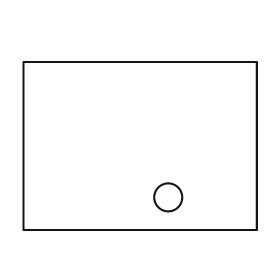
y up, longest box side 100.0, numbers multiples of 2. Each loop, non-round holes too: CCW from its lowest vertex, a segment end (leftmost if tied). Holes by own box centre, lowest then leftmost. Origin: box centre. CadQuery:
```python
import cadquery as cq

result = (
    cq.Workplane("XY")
    .moveTo(-50.0, -36.0)
    .lineTo(50.0, -36.0)
    .lineTo(50.0, 36.0)
    .lineTo(-50.0, 36.0)
    .close()
    .moveTo(12.0, -22.0)
    .circle(6.0)
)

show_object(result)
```